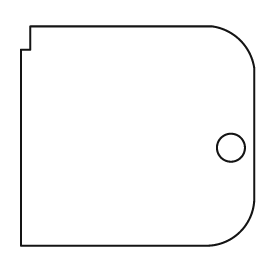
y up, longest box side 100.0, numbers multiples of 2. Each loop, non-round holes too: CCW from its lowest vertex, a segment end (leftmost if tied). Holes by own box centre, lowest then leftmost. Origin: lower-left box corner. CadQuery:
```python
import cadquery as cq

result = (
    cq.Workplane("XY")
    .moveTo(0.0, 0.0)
    .lineTo(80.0, 0.0)
    .threePointArc((94.0, 6.0), (100.0, 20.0))
    .lineTo(100.0, 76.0)
    .threePointArc((94.0, 88.0), (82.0, 94.0))
    .lineTo(4.0, 94.0)
    .lineTo(4.0, 84.0)
    .lineTo(0.0, 84.0)
    .close()
    .moveTo(90.0, 42.0)
    .circle(6.0)
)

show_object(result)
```